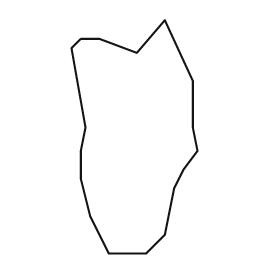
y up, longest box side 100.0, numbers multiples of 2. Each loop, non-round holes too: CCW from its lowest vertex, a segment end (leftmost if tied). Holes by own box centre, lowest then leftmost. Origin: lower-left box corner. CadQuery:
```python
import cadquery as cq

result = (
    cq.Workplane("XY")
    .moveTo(16.0, 0.0)
    .lineTo(32.0, 0.0)
    .lineTo(40.0, 8.0)
    .lineTo(44.0, 28.0)
    .lineTo(48.0, 36.0)
    .lineTo(54.0, 44.0)
    .lineTo(52.0, 54.0)
    .lineTo(52.0, 74.0)
    .lineTo(40.0, 100.0)
    .lineTo(28.0, 86.0)
    .lineTo(12.0, 92.0)
    .lineTo(4.0, 92.0)
    .lineTo(0.0, 88.0)
    .lineTo(6.0, 54.0)
    .lineTo(4.0, 44.0)
    .lineTo(4.0, 32.0)
    .lineTo(8.0, 16.0)
    .close()
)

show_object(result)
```